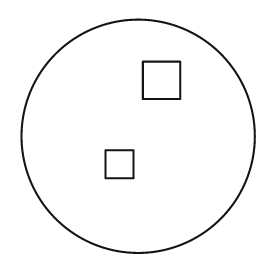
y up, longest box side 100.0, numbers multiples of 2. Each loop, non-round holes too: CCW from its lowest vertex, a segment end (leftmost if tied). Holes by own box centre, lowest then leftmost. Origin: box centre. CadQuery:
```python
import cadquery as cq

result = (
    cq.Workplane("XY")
    .moveTo(0.0, 0.0)
    .circle(50.0)
    .moveTo(-14.0, -18.0)
    .lineTo(-2.0, -18.0)
    .lineTo(-2.0, -6.0)
    .lineTo(-14.0, -6.0)
    .close()
    .moveTo(2.0, 16.0)
    .lineTo(18.0, 16.0)
    .lineTo(18.0, 32.0)
    .lineTo(2.0, 32.0)
    .close()
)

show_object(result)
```